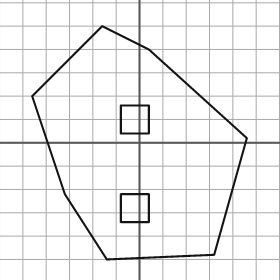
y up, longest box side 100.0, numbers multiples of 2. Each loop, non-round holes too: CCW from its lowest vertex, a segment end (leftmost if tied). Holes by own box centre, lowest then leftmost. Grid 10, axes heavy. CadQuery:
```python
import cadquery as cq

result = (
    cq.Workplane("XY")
    .moveTo(-14.0, -50.0)
    .lineTo(32.0, -48.0)
    .lineTo(46.0, 2.0)
    .lineTo(4.0, 40.0)
    .lineTo(-16.0, 50.0)
    .lineTo(-46.0, 20.0)
    .lineTo(-32.0, -22.0)
    .close()
    .moveTo(-8.0, -34.0)
    .lineTo(4.0, -34.0)
    .lineTo(4.0, -22.0)
    .lineTo(-8.0, -22.0)
    .close()
    .moveTo(-8.0, 4.0)
    .lineTo(4.0, 4.0)
    .lineTo(4.0, 16.0)
    .lineTo(-8.0, 16.0)
    .close()
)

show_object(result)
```